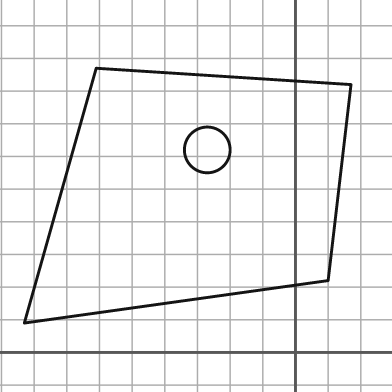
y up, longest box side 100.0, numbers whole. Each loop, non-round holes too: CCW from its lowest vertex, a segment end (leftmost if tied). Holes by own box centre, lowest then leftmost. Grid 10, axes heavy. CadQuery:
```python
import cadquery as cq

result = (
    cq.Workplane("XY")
    .moveTo(-83.0, 9.0)
    .lineTo(10.0, 22.0)
    .lineTo(17.0, 82.0)
    .lineTo(-61.0, 87.0)
    .close()
    .moveTo(-27.0, 62.0)
    .circle(7.0)
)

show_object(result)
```